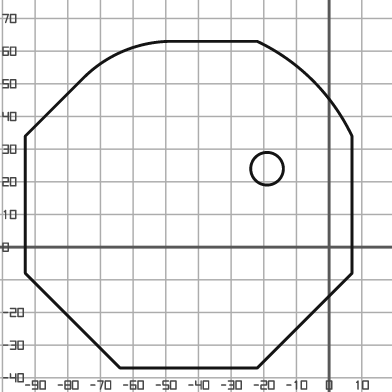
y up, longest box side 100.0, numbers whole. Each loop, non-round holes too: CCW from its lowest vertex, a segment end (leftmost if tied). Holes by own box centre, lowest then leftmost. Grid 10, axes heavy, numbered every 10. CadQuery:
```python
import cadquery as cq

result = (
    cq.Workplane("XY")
    .moveTo(-64.0, -37.0)
    .lineTo(-22.0, -37.0)
    .lineTo(7.0, -8.0)
    .lineTo(7.0, 34.0)
    .threePointArc((-5.0, 51.0), (-22.0, 63.0))
    .lineTo(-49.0, 63.0)
    .threePointArc((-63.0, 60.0), (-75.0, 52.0))
    .lineTo(-93.0, 34.0)
    .lineTo(-93.0, -8.0)
    .close()
    .moveTo(-19.0, 24.0)
    .circle(5.0)
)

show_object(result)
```